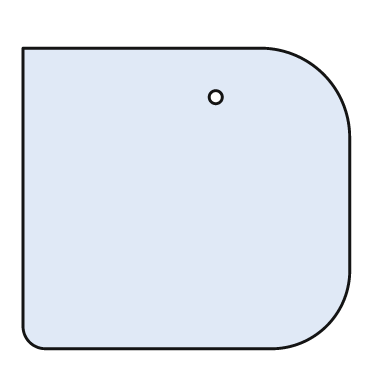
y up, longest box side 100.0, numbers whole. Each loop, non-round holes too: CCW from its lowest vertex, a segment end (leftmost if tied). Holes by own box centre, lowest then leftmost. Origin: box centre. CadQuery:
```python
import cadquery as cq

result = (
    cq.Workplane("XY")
    .moveTo(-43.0, -46.0)
    .lineTo(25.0, -46.0)
    .threePointArc((43.0, -39.0), (50.0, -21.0))
    .lineTo(50.0, 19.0)
    .threePointArc((42.0, 38.0), (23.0, 46.0))
    .lineTo(-50.0, 46.0)
    .lineTo(-50.0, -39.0)
    .threePointArc((-48.0, -44.0), (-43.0, -46.0))
    .close()
    .moveTo(9.0, 31.0)
    .circle(2.0)
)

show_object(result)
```